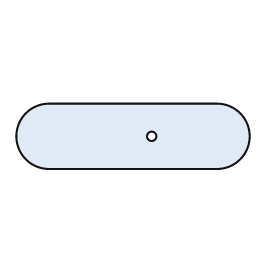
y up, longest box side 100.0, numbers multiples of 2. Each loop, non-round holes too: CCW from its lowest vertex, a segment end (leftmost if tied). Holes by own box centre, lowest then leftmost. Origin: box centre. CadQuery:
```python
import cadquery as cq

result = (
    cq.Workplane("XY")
    .moveTo(-36.0, -14.0)
    .lineTo(36.0, -14.0)
    .threePointArc((50.0, 0.0), (36.0, 14.0))
    .lineTo(-36.0, 14.0)
    .threePointArc((-50.0, 0.0), (-36.0, -14.0))
    .close()
    .moveTo(8.0, 0.0)
    .circle(2.0)
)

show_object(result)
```